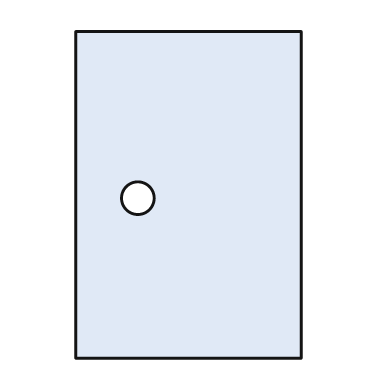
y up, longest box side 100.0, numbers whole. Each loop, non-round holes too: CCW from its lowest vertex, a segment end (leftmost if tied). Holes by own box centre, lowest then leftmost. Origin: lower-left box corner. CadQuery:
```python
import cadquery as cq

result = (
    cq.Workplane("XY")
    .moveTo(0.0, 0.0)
    .lineTo(69.0, 0.0)
    .lineTo(69.0, 100.0)
    .lineTo(0.0, 100.0)
    .close()
    .moveTo(19.0, 49.0)
    .circle(5.0)
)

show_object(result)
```